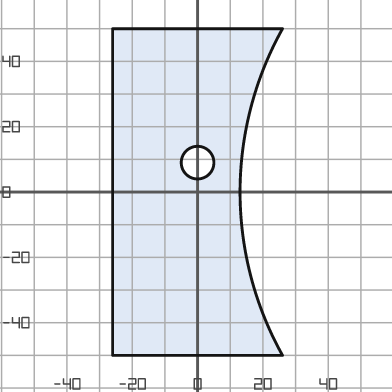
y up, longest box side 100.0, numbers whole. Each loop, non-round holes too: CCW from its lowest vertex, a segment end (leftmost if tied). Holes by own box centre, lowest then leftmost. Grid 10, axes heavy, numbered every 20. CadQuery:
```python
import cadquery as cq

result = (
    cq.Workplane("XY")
    .moveTo(-26.0, -50.0)
    .lineTo(26.0, -50.0)
    .threePointArc((13.0, 0.0), (26.0, 50.0))
    .lineTo(-26.0, 50.0)
    .close()
    .moveTo(0.0, 9.0)
    .circle(5.0)
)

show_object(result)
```